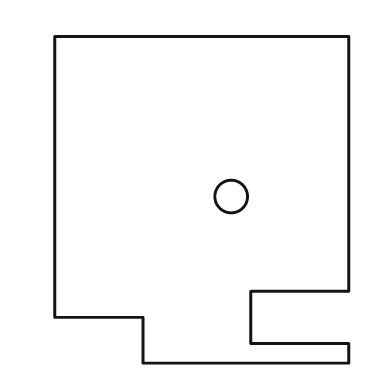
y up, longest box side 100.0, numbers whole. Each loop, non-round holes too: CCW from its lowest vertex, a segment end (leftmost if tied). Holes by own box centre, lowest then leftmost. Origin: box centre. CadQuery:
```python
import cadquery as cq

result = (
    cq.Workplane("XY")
    .moveTo(-18.0, -50.0)
    .lineTo(45.0, -50.0)
    .lineTo(45.0, -44.0)
    .lineTo(15.0, -44.0)
    .lineTo(15.0, -28.0)
    .lineTo(45.0, -28.0)
    .lineTo(45.0, 50.0)
    .lineTo(-45.0, 50.0)
    .lineTo(-45.0, -36.0)
    .lineTo(-18.0, -36.0)
    .close()
    .moveTo(9.0, 1.0)
    .circle(5.0)
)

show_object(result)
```